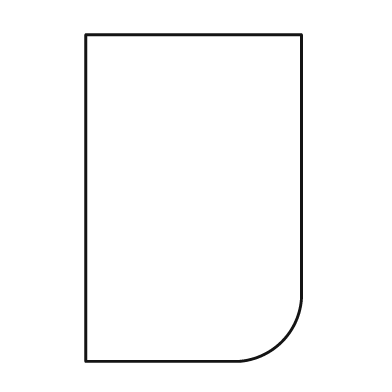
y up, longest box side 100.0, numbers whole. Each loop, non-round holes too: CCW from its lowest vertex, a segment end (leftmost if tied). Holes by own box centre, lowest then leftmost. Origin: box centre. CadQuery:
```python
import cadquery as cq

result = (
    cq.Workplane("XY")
    .moveTo(-33.0, -50.0)
    .lineTo(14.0, -50.0)
    .threePointArc((27.0, -44.0), (33.0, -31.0))
    .lineTo(33.0, 50.0)
    .lineTo(-33.0, 50.0)
    .close()
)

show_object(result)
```